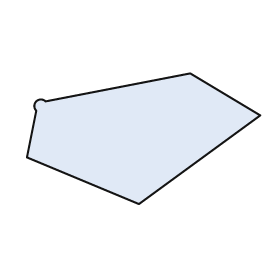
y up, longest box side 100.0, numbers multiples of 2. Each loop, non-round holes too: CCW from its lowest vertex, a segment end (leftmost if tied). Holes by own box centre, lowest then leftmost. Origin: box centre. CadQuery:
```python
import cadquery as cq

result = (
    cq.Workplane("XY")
    .moveTo(-2.0, -28.0)
    .lineTo(50.0, 10.0)
    .lineTo(20.0, 28.0)
    .lineTo(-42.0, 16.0)
    .threePointArc((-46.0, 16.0), (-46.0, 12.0))
    .lineTo(-50.0, -8.0)
    .close()
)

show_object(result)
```